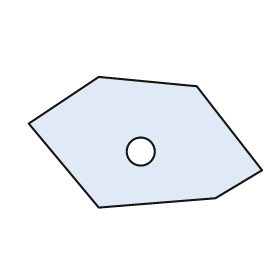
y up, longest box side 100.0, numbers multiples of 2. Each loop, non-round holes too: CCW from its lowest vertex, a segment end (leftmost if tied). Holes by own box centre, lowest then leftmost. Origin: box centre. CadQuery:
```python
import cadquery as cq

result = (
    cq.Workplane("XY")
    .moveTo(-20.0, -28.0)
    .lineTo(30.0, -24.0)
    .lineTo(50.0, -12.0)
    .lineTo(22.0, 24.0)
    .lineTo(-20.0, 28.0)
    .lineTo(-50.0, 8.0)
    .close()
    .moveTo(-2.0, -4.0)
    .circle(6.0)
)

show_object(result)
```